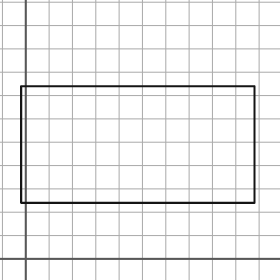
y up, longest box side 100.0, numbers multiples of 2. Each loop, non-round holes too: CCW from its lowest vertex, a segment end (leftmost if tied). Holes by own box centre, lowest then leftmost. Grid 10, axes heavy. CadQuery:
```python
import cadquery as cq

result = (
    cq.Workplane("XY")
    .moveTo(-2.0, 24.0)
    .lineTo(98.0, 24.0)
    .lineTo(98.0, 74.0)
    .lineTo(-2.0, 74.0)
    .close()
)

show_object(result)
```